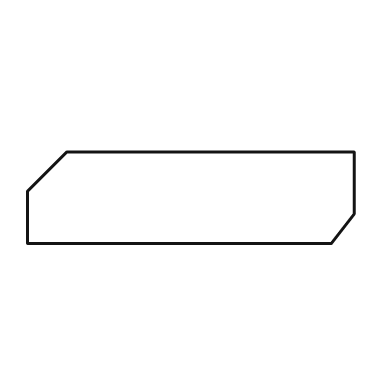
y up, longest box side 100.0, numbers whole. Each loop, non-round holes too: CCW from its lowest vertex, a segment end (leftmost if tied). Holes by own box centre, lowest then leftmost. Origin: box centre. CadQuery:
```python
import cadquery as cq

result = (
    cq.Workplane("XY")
    .moveTo(-50.0, -14.0)
    .lineTo(43.0, -14.0)
    .lineTo(50.0, -5.0)
    .lineTo(50.0, 14.0)
    .lineTo(-38.0, 14.0)
    .lineTo(-50.0, 2.0)
    .close()
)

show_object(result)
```